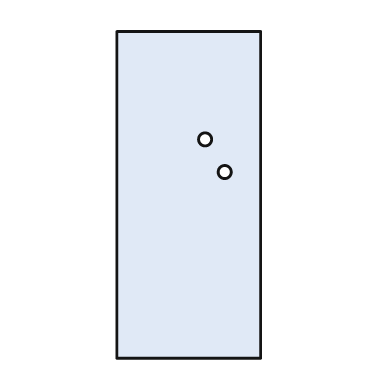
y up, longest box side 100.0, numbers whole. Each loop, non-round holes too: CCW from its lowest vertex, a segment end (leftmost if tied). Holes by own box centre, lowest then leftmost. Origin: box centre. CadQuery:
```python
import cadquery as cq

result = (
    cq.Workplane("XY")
    .moveTo(-22.0, -50.0)
    .lineTo(22.0, -50.0)
    .lineTo(22.0, 50.0)
    .lineTo(-22.0, 50.0)
    .close()
    .moveTo(11.0, 7.0)
    .circle(2.0)
    .moveTo(5.0, 17.0)
    .circle(2.0)
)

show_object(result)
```